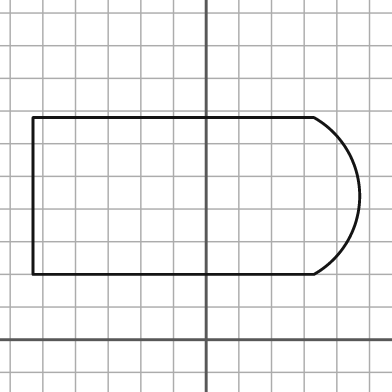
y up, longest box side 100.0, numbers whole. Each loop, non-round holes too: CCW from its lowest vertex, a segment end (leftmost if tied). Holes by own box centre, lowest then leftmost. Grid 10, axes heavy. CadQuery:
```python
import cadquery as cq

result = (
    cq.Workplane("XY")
    .moveTo(-53.0, 20.0)
    .lineTo(33.0, 20.0)
    .threePointArc((47.0, 44.0), (33.0, 68.0))
    .lineTo(-53.0, 68.0)
    .close()
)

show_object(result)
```